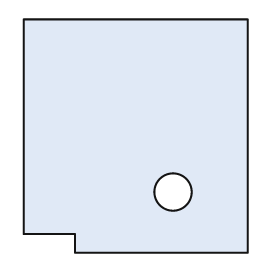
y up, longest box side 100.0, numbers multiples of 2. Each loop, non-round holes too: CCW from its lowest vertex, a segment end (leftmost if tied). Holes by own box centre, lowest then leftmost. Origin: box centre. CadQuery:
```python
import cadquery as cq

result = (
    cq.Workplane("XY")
    .moveTo(-26.0, -50.0)
    .lineTo(48.0, -50.0)
    .lineTo(48.0, 50.0)
    .lineTo(-48.0, 50.0)
    .lineTo(-48.0, -42.0)
    .lineTo(-26.0, -42.0)
    .close()
    .moveTo(16.0, -24.0)
    .circle(8.0)
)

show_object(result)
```